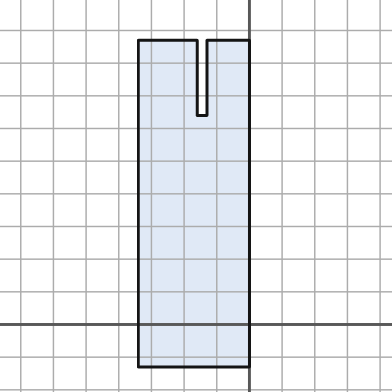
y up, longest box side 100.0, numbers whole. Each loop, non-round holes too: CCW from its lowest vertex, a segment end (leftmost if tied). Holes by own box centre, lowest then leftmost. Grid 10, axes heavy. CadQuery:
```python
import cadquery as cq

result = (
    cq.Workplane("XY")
    .moveTo(-34.0, -13.0)
    .lineTo(0.0, -13.0)
    .lineTo(0.0, 87.0)
    .lineTo(-13.0, 87.0)
    .lineTo(-13.0, 64.0)
    .lineTo(-16.0, 64.0)
    .lineTo(-16.0, 87.0)
    .lineTo(-34.0, 87.0)
    .close()
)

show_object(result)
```